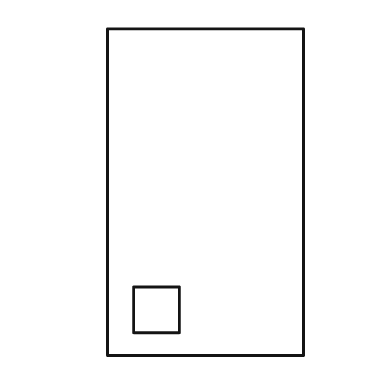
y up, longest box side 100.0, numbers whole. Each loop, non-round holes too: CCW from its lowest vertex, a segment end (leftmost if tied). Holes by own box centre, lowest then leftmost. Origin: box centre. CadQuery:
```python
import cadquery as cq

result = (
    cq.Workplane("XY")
    .moveTo(-30.0, -50.0)
    .lineTo(30.0, -50.0)
    .lineTo(30.0, 50.0)
    .lineTo(-30.0, 50.0)
    .close()
    .moveTo(-22.0, -43.0)
    .lineTo(-8.0, -43.0)
    .lineTo(-8.0, -29.0)
    .lineTo(-22.0, -29.0)
    .close()
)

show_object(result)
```